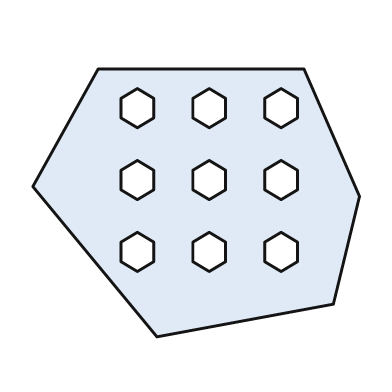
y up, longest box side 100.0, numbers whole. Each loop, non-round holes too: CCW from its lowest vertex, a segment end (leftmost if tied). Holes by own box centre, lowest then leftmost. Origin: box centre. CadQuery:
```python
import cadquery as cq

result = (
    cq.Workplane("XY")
    .moveTo(-12.0, -41.0)
    .lineTo(42.0, -31.0)
    .lineTo(50.0, 2.0)
    .lineTo(33.0, 41.0)
    .lineTo(-30.0, 41.0)
    .lineTo(-50.0, 5.0)
    .close()
    .moveTo(-18.0, -21.0)
    .lineTo(-13.0, -18.0)
    .lineTo(-13.0, -12.0)
    .lineTo(-18.0, -9.0)
    .lineTo(-23.0, -12.0)
    .lineTo(-23.0, -18.0)
    .close()
    .moveTo(4.0, -21.0)
    .lineTo(9.0, -18.0)
    .lineTo(9.0, -12.0)
    .lineTo(4.0, -9.0)
    .lineTo(-1.0, -12.0)
    .lineTo(-1.0, -18.0)
    .close()
    .moveTo(26.0, -21.0)
    .lineTo(31.0, -18.0)
    .lineTo(31.0, -12.0)
    .lineTo(26.0, -9.0)
    .lineTo(21.0, -12.0)
    .lineTo(21.0, -18.0)
    .close()
    .moveTo(-18.0, 1.0)
    .lineTo(-13.0, 4.0)
    .lineTo(-13.0, 10.0)
    .lineTo(-18.0, 13.0)
    .lineTo(-23.0, 10.0)
    .lineTo(-23.0, 4.0)
    .close()
    .moveTo(4.0, 1.0)
    .lineTo(9.0, 4.0)
    .lineTo(9.0, 10.0)
    .lineTo(4.0, 13.0)
    .lineTo(-1.0, 10.0)
    .lineTo(-1.0, 4.0)
    .close()
    .moveTo(26.0, 1.0)
    .lineTo(31.0, 4.0)
    .lineTo(31.0, 10.0)
    .lineTo(26.0, 13.0)
    .lineTo(21.0, 10.0)
    .lineTo(21.0, 4.0)
    .close()
    .moveTo(-18.0, 23.0)
    .lineTo(-13.0, 26.0)
    .lineTo(-13.0, 32.0)
    .lineTo(-18.0, 35.0)
    .lineTo(-23.0, 32.0)
    .lineTo(-23.0, 26.0)
    .close()
    .moveTo(4.0, 23.0)
    .lineTo(9.0, 26.0)
    .lineTo(9.0, 32.0)
    .lineTo(4.0, 35.0)
    .lineTo(-1.0, 32.0)
    .lineTo(-1.0, 26.0)
    .close()
    .moveTo(26.0, 23.0)
    .lineTo(31.0, 26.0)
    .lineTo(31.0, 32.0)
    .lineTo(26.0, 35.0)
    .lineTo(21.0, 32.0)
    .lineTo(21.0, 26.0)
    .close()
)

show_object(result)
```